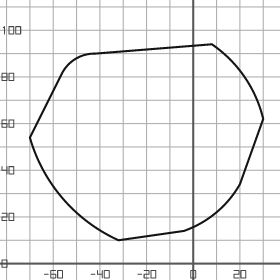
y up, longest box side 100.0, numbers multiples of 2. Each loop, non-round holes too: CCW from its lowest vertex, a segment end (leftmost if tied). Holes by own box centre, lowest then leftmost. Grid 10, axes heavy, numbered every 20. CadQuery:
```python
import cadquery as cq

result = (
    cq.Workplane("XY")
    .moveTo(-32.0, 10.0)
    .lineTo(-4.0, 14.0)
    .threePointArc((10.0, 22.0), (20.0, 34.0))
    .lineTo(30.0, 62.0)
    .threePointArc((22.0, 80.0), (8.0, 94.0))
    .lineTo(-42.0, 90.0)
    .threePointArc((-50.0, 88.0), (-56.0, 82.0))
    .lineTo(-70.0, 54.0)
    .threePointArc((-56.0, 28.0), (-32.0, 10.0))
    .close()
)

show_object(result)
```